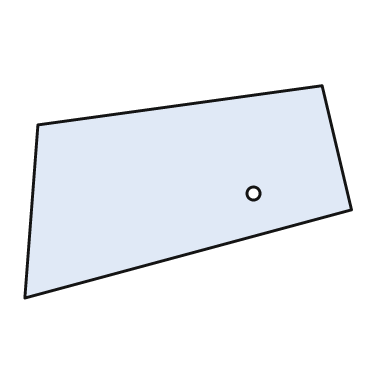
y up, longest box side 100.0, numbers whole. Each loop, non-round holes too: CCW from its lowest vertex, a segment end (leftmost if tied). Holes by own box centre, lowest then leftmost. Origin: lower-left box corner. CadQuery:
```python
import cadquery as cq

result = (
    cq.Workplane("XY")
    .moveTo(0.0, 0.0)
    .lineTo(100.0, 27.0)
    .lineTo(91.0, 65.0)
    .lineTo(4.0, 53.0)
    .close()
    .moveTo(70.0, 32.0)
    .circle(2.0)
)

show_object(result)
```